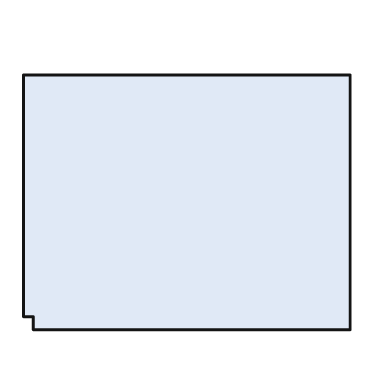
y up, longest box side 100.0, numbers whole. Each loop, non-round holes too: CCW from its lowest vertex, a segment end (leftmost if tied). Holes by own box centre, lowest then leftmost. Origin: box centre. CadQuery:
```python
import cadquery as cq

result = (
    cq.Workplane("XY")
    .moveTo(-47.0, -39.0)
    .lineTo(50.0, -39.0)
    .lineTo(50.0, 39.0)
    .lineTo(-50.0, 39.0)
    .lineTo(-50.0, -35.0)
    .lineTo(-47.0, -35.0)
    .close()
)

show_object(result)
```